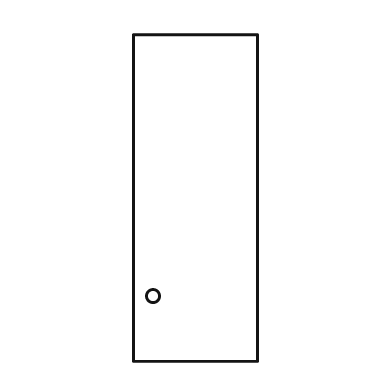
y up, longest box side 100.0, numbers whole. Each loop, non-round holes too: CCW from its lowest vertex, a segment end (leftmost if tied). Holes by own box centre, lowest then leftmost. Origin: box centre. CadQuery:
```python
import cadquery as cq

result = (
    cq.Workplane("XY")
    .moveTo(-19.0, -50.0)
    .lineTo(19.0, -50.0)
    .lineTo(19.0, 50.0)
    .lineTo(-19.0, 50.0)
    .close()
    .moveTo(-13.0, -30.0)
    .circle(2.0)
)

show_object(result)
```